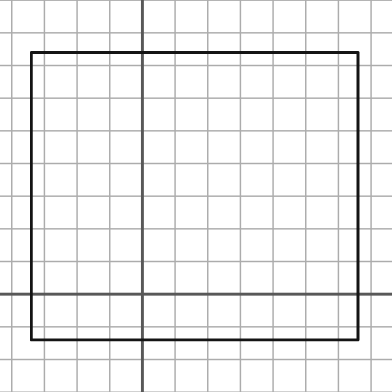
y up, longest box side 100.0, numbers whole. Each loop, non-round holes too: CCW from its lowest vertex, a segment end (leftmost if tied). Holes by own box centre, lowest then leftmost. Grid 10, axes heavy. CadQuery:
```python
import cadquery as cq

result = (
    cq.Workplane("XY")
    .moveTo(-34.0, -14.0)
    .lineTo(66.0, -14.0)
    .lineTo(66.0, 74.0)
    .lineTo(-34.0, 74.0)
    .close()
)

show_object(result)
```